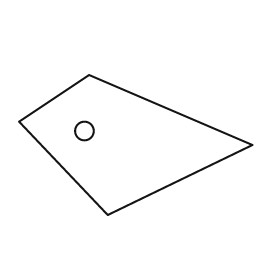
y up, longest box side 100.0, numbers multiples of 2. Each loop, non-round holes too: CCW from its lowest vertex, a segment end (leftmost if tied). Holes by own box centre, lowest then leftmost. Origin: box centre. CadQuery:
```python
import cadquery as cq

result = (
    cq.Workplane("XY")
    .moveTo(-12.0, -30.0)
    .lineTo(50.0, 0.0)
    .lineTo(-20.0, 30.0)
    .lineTo(-50.0, 10.0)
    .close()
    .moveTo(-22.0, 6.0)
    .circle(4.0)
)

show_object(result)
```